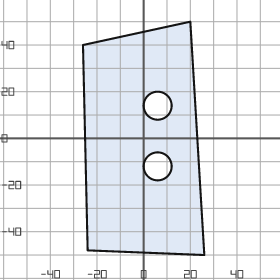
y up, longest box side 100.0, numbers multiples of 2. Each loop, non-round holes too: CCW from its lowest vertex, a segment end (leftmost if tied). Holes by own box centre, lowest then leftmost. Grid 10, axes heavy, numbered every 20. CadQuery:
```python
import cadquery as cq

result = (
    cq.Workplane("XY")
    .moveTo(26.0, -50.0)
    .lineTo(20.0, 50.0)
    .lineTo(-26.0, 40.0)
    .lineTo(-24.0, -48.0)
    .close()
    .moveTo(6.0, -12.0)
    .circle(6.0)
    .moveTo(6.0, 14.0)
    .circle(6.0)
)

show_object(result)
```